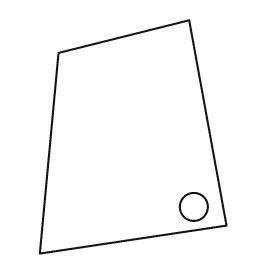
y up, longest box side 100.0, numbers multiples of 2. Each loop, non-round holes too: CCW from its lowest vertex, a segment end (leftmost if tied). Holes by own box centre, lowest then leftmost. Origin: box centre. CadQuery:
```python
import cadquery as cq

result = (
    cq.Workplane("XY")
    .moveTo(-40.0, -50.0)
    .lineTo(40.0, -38.0)
    .lineTo(24.0, 50.0)
    .lineTo(-32.0, 36.0)
    .close()
    .moveTo(26.0, -30.0)
    .circle(6.0)
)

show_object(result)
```